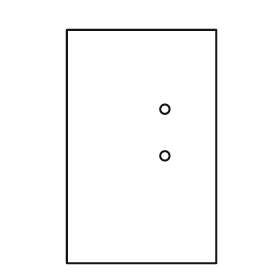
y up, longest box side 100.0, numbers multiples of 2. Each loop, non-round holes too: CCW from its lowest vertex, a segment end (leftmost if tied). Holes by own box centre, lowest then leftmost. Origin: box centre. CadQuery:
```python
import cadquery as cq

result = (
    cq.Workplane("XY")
    .moveTo(-32.0, -50.0)
    .lineTo(32.0, -50.0)
    .lineTo(32.0, 50.0)
    .lineTo(-32.0, 50.0)
    .close()
    .moveTo(10.0, -4.0)
    .circle(2.0)
    .moveTo(10.0, 16.0)
    .circle(2.0)
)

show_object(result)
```